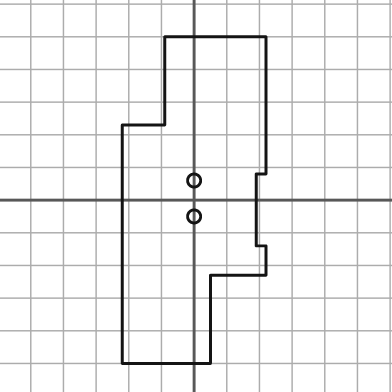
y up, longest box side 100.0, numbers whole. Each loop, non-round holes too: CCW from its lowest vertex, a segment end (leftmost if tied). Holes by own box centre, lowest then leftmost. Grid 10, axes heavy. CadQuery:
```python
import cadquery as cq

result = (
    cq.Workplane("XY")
    .moveTo(-22.0, -50.0)
    .lineTo(5.0, -50.0)
    .lineTo(5.0, -23.0)
    .lineTo(22.0, -23.0)
    .lineTo(22.0, -14.0)
    .lineTo(19.0, -14.0)
    .lineTo(19.0, 8.0)
    .lineTo(22.0, 8.0)
    .lineTo(22.0, 50.0)
    .lineTo(-9.0, 50.0)
    .lineTo(-9.0, 23.0)
    .lineTo(-22.0, 23.0)
    .close()
    .moveTo(0.0, -5.0)
    .circle(2.0)
    .moveTo(0.0, 6.0)
    .circle(2.0)
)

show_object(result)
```